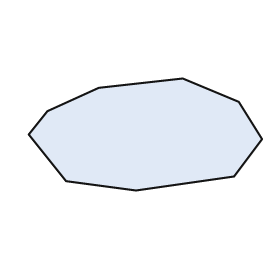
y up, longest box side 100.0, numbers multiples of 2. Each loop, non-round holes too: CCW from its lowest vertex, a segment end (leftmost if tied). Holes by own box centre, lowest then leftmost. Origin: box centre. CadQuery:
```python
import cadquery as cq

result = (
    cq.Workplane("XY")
    .moveTo(-4.0, -24.0)
    .lineTo(38.0, -18.0)
    .lineTo(50.0, -2.0)
    .lineTo(40.0, 14.0)
    .lineTo(16.0, 24.0)
    .lineTo(-20.0, 20.0)
    .lineTo(-42.0, 10.0)
    .lineTo(-50.0, 0.0)
    .lineTo(-34.0, -20.0)
    .close()
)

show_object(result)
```